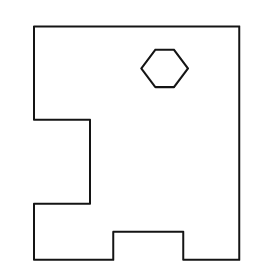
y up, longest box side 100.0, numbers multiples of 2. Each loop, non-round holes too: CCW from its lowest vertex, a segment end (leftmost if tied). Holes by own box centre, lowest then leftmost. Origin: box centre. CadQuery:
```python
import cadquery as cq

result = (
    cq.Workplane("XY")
    .moveTo(-44.0, -50.0)
    .lineTo(-10.0, -50.0)
    .lineTo(-10.0, -38.0)
    .lineTo(20.0, -38.0)
    .lineTo(20.0, -50.0)
    .lineTo(44.0, -50.0)
    .lineTo(44.0, 50.0)
    .lineTo(-44.0, 50.0)
    .lineTo(-44.0, 10.0)
    .lineTo(-20.0, 10.0)
    .lineTo(-20.0, -26.0)
    .lineTo(-44.0, -26.0)
    .close()
    .moveTo(8.0, 24.0)
    .lineTo(16.0, 24.0)
    .lineTo(22.0, 32.0)
    .lineTo(16.0, 40.0)
    .lineTo(8.0, 40.0)
    .lineTo(2.0, 32.0)
    .close()
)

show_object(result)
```